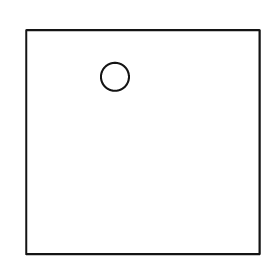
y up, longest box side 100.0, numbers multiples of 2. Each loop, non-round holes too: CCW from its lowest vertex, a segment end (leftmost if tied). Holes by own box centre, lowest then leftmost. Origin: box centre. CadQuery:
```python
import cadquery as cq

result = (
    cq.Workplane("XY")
    .moveTo(-50.0, -48.0)
    .lineTo(50.0, -48.0)
    .lineTo(50.0, 48.0)
    .lineTo(-50.0, 48.0)
    .close()
    .moveTo(-12.0, 28.0)
    .circle(6.0)
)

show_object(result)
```